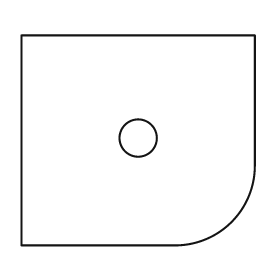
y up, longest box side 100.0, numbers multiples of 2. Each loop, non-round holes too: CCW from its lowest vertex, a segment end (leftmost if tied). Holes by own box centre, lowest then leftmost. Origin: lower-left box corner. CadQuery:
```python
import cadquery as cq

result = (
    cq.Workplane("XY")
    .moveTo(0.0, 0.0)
    .lineTo(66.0, 0.0)
    .threePointArc((90.0, 10.0), (100.0, 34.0))
    .lineTo(100.0, 90.0)
    .lineTo(0.0, 90.0)
    .close()
    .moveTo(50.0, 46.0)
    .circle(8.0)
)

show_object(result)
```